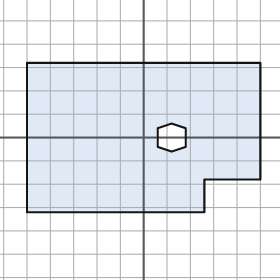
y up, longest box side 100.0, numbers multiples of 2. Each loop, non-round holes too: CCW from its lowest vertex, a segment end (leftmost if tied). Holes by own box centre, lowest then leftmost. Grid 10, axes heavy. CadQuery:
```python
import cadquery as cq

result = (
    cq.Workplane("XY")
    .moveTo(-50.0, -32.0)
    .lineTo(26.0, -32.0)
    .lineTo(26.0, -18.0)
    .lineTo(50.0, -18.0)
    .lineTo(50.0, 32.0)
    .lineTo(-50.0, 32.0)
    .close()
    .moveTo(12.0, -6.0)
    .lineTo(18.0, -4.0)
    .lineTo(18.0, 4.0)
    .lineTo(12.0, 6.0)
    .lineTo(6.0, 4.0)
    .lineTo(6.0, -4.0)
    .close()
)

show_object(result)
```